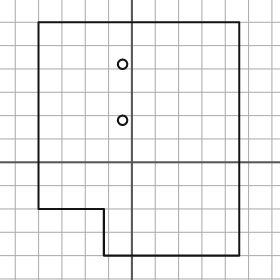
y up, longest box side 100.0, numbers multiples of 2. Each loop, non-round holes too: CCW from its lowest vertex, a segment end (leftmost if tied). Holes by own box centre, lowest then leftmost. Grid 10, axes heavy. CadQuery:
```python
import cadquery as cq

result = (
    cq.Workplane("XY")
    .moveTo(-12.0, -40.0)
    .lineTo(46.0, -40.0)
    .lineTo(46.0, 60.0)
    .lineTo(-40.0, 60.0)
    .lineTo(-40.0, -20.0)
    .lineTo(-12.0, -20.0)
    .close()
    .moveTo(-4.0, 18.0)
    .circle(2.0)
    .moveTo(-4.0, 42.0)
    .circle(2.0)
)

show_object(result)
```